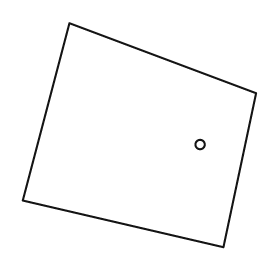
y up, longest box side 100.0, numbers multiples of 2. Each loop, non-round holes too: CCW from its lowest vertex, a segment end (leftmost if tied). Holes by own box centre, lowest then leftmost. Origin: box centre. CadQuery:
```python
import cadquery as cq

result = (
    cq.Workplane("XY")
    .moveTo(36.0, -48.0)
    .lineTo(50.0, 18.0)
    .lineTo(-30.0, 48.0)
    .lineTo(-50.0, -28.0)
    .close()
    .moveTo(26.0, -4.0)
    .circle(2.0)
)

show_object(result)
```